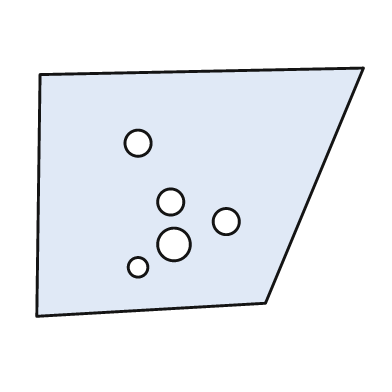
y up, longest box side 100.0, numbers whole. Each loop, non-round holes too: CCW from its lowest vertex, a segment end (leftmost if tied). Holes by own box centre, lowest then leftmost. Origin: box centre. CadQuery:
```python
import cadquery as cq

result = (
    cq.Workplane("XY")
    .moveTo(-50.0, -38.0)
    .lineTo(20.0, -34.0)
    .lineTo(50.0, 38.0)
    .lineTo(-49.0, 36.0)
    .close()
    .moveTo(-19.0, -23.0)
    .circle(3.0)
    .moveTo(-8.0, -16.0)
    .circle(5.0)
    .moveTo(8.0, -9.0)
    .circle(4.0)
    .moveTo(-9.0, -3.0)
    .circle(4.0)
    .moveTo(-19.0, 15.0)
    .circle(4.0)
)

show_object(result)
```